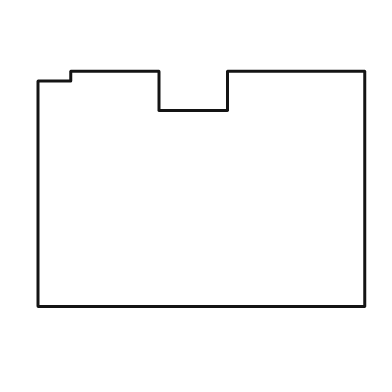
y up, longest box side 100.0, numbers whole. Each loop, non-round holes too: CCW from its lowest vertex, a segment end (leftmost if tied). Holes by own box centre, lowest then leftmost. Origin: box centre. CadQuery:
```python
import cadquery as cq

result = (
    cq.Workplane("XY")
    .moveTo(-50.0, -36.0)
    .lineTo(50.0, -36.0)
    .lineTo(50.0, 36.0)
    .lineTo(8.0, 36.0)
    .lineTo(8.0, 24.0)
    .lineTo(-13.0, 24.0)
    .lineTo(-13.0, 36.0)
    .lineTo(-40.0, 36.0)
    .lineTo(-40.0, 33.0)
    .lineTo(-50.0, 33.0)
    .close()
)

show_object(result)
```